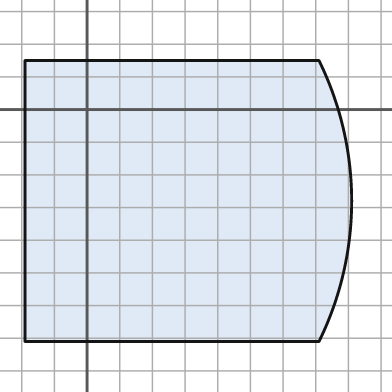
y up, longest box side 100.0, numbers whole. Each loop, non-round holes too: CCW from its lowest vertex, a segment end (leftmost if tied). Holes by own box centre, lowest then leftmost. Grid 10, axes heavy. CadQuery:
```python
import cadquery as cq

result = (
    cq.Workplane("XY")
    .moveTo(-19.0, -71.0)
    .lineTo(71.0, -71.0)
    .threePointArc((81.0, -28.0), (71.0, 15.0))
    .lineTo(-19.0, 15.0)
    .close()
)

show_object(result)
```